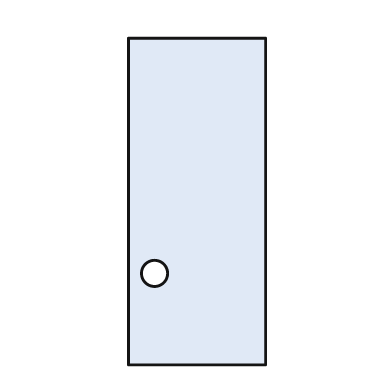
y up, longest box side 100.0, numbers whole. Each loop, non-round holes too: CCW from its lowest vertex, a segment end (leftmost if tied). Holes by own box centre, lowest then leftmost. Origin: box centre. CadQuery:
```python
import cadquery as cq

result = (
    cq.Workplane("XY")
    .moveTo(-21.0, -50.0)
    .lineTo(21.0, -50.0)
    .lineTo(21.0, 50.0)
    .lineTo(-21.0, 50.0)
    .close()
    .moveTo(-13.0, -22.0)
    .circle(4.0)
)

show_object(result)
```